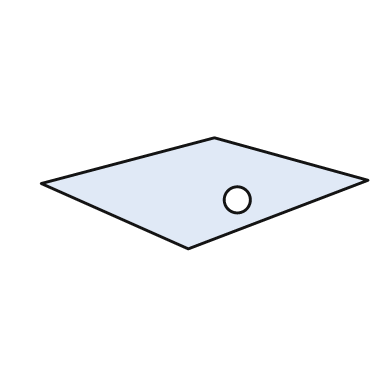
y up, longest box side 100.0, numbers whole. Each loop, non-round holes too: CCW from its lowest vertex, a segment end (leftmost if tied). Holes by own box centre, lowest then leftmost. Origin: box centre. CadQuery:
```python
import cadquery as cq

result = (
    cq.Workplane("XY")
    .moveTo(-5.0, -17.0)
    .lineTo(50.0, 4.0)
    .lineTo(3.0, 17.0)
    .lineTo(-50.0, 3.0)
    .close()
    .moveTo(10.0, -2.0)
    .circle(4.0)
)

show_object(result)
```